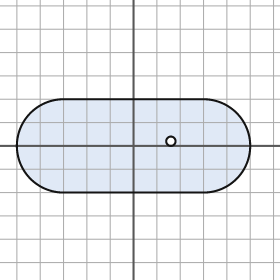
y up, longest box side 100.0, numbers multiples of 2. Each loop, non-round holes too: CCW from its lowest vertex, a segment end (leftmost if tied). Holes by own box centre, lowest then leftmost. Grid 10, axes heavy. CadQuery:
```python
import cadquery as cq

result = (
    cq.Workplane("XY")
    .moveTo(-30.0, -20.0)
    .lineTo(30.0, -20.0)
    .threePointArc((50.0, 0.0), (30.0, 20.0))
    .lineTo(-30.0, 20.0)
    .threePointArc((-50.0, 0.0), (-30.0, -20.0))
    .close()
    .moveTo(16.0, 2.0)
    .circle(2.0)
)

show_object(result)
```